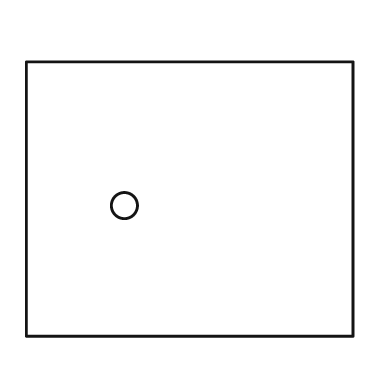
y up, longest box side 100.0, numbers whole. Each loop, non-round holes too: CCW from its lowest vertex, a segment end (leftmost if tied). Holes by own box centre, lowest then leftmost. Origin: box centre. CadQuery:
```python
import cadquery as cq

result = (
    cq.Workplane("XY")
    .moveTo(-50.0, -42.0)
    .lineTo(50.0, -42.0)
    .lineTo(50.0, 42.0)
    .lineTo(-50.0, 42.0)
    .close()
    .moveTo(-20.0, -2.0)
    .circle(4.0)
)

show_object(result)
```